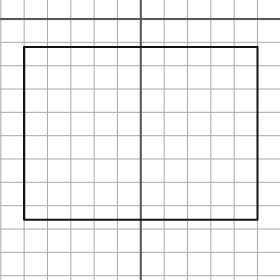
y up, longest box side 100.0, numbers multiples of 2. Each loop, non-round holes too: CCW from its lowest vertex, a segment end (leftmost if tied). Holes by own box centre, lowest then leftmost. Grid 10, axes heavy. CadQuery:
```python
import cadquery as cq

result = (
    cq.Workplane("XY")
    .moveTo(-50.0, -86.0)
    .lineTo(50.0, -86.0)
    .lineTo(50.0, -12.0)
    .lineTo(-50.0, -12.0)
    .close()
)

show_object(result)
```